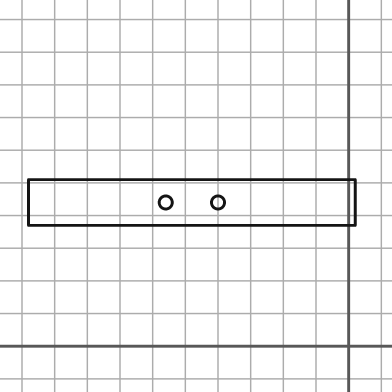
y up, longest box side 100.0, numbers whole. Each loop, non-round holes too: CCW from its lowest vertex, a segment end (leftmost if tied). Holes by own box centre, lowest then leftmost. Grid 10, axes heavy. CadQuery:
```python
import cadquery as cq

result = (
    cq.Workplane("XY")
    .moveTo(-98.0, 37.0)
    .lineTo(2.0, 37.0)
    .lineTo(2.0, 51.0)
    .lineTo(-98.0, 51.0)
    .close()
    .moveTo(-56.0, 44.0)
    .circle(2.0)
    .moveTo(-40.0, 44.0)
    .circle(2.0)
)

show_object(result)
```